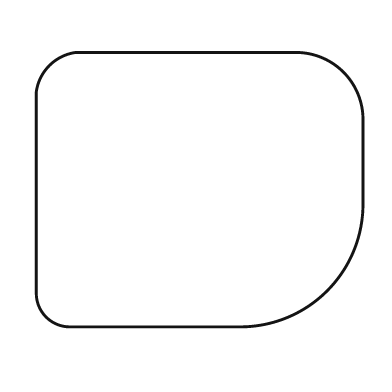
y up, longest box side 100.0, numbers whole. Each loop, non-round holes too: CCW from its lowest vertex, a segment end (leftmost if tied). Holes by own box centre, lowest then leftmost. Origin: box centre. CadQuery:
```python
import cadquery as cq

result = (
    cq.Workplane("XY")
    .moveTo(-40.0, -42.0)
    .lineTo(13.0, -42.0)
    .threePointArc((39.0, -31.0), (50.0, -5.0))
    .lineTo(50.0, 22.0)
    .threePointArc((44.0, 36.0), (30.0, 42.0))
    .lineTo(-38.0, 42.0)
    .threePointArc((-46.0, 38.0), (-50.0, 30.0))
    .lineTo(-50.0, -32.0)
    .threePointArc((-47.0, -39.0), (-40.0, -42.0))
    .close()
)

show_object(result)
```